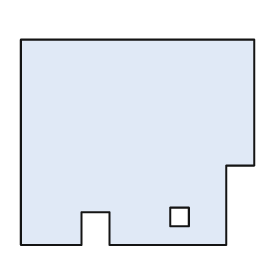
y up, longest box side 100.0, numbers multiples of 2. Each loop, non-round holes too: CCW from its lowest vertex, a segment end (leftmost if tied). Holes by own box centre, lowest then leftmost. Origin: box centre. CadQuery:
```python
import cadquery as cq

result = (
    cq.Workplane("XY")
    .moveTo(-50.0, -44.0)
    .lineTo(-24.0, -44.0)
    .lineTo(-24.0, -30.0)
    .lineTo(-12.0, -30.0)
    .lineTo(-12.0, -44.0)
    .lineTo(38.0, -44.0)
    .lineTo(38.0, -10.0)
    .lineTo(50.0, -10.0)
    .lineTo(50.0, 44.0)
    .lineTo(-50.0, 44.0)
    .close()
    .moveTo(14.0, -36.0)
    .lineTo(22.0, -36.0)
    .lineTo(22.0, -28.0)
    .lineTo(14.0, -28.0)
    .close()
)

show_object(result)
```